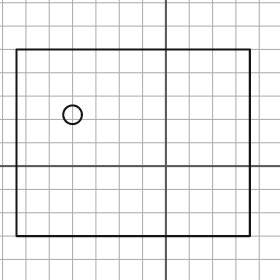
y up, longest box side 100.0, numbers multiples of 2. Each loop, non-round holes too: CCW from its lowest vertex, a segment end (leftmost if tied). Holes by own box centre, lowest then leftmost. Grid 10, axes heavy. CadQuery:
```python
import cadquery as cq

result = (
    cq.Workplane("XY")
    .moveTo(-64.0, -30.0)
    .lineTo(36.0, -30.0)
    .lineTo(36.0, 50.0)
    .lineTo(-64.0, 50.0)
    .close()
    .moveTo(-40.0, 22.0)
    .circle(4.0)
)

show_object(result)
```